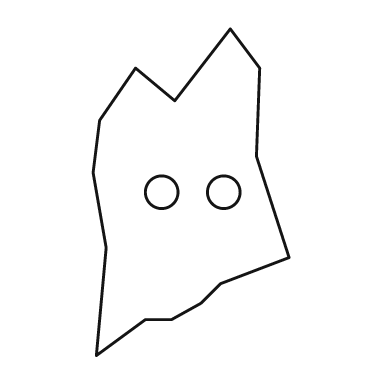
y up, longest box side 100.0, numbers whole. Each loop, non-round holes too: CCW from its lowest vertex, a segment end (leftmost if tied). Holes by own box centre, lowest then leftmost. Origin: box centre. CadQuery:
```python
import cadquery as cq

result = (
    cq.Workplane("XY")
    .moveTo(-29.0, -50.0)
    .lineTo(-14.0, -39.0)
    .lineTo(-6.0, -39.0)
    .lineTo(3.0, -34.0)
    .lineTo(9.0, -28.0)
    .lineTo(30.0, -20.0)
    .lineTo(20.0, 11.0)
    .lineTo(21.0, 38.0)
    .lineTo(12.0, 50.0)
    .lineTo(-5.0, 28.0)
    .lineTo(-17.0, 38.0)
    .lineTo(-28.0, 22.0)
    .lineTo(-30.0, 6.0)
    .lineTo(-26.0, -17.0)
    .close()
    .moveTo(-9.0, 0.0)
    .circle(5.0)
    .moveTo(10.0, 0.0)
    .circle(5.0)
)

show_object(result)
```